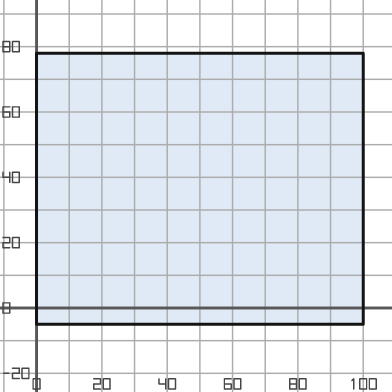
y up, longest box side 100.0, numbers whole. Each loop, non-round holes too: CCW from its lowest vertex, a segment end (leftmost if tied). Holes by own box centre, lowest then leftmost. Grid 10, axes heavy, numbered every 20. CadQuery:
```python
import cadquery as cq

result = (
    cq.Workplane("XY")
    .moveTo(0.0, -5.0)
    .lineTo(100.0, -5.0)
    .lineTo(100.0, 78.0)
    .lineTo(0.0, 78.0)
    .close()
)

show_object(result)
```